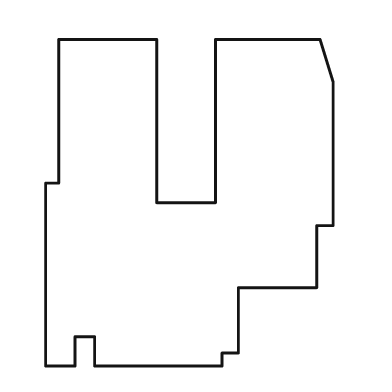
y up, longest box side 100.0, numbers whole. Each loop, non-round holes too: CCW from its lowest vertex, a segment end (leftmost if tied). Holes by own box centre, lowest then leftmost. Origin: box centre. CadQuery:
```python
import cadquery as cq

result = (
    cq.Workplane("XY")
    .moveTo(-44.0, -50.0)
    .lineTo(-35.0, -50.0)
    .lineTo(-35.0, -41.0)
    .lineTo(-29.0, -41.0)
    .lineTo(-29.0, -50.0)
    .lineTo(10.0, -50.0)
    .lineTo(10.0, -46.0)
    .lineTo(15.0, -46.0)
    .lineTo(15.0, -26.0)
    .lineTo(39.0, -26.0)
    .lineTo(39.0, -7.0)
    .lineTo(44.0, -7.0)
    .lineTo(44.0, 37.0)
    .lineTo(40.0, 50.0)
    .lineTo(8.0, 50.0)
    .lineTo(8.0, 0.0)
    .lineTo(-10.0, 0.0)
    .lineTo(-10.0, 50.0)
    .lineTo(-40.0, 50.0)
    .lineTo(-40.0, 6.0)
    .lineTo(-44.0, 6.0)
    .close()
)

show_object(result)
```